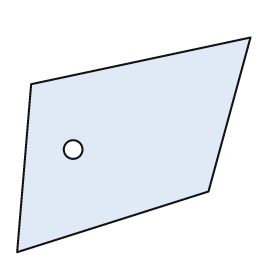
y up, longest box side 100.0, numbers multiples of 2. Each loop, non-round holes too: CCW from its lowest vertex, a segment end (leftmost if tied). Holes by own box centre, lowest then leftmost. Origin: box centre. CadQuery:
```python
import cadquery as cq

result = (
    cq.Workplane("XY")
    .moveTo(-50.0, -46.0)
    .lineTo(32.0, -20.0)
    .lineTo(50.0, 46.0)
    .lineTo(-44.0, 26.0)
    .close()
    .moveTo(-26.0, -2.0)
    .circle(4.0)
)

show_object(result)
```